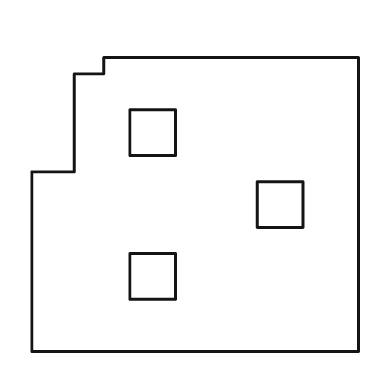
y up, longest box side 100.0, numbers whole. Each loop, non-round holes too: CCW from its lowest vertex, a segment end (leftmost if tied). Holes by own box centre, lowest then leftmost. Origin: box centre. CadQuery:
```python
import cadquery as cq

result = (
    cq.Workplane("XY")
    .moveTo(-50.0, -45.0)
    .lineTo(50.0, -45.0)
    .lineTo(50.0, 45.0)
    .lineTo(-28.0, 45.0)
    .lineTo(-28.0, 40.0)
    .lineTo(-37.0, 40.0)
    .lineTo(-37.0, 10.0)
    .lineTo(-50.0, 10.0)
    .close()
    .moveTo(-20.0, -29.0)
    .lineTo(-6.0, -29.0)
    .lineTo(-6.0, -15.0)
    .lineTo(-20.0, -15.0)
    .close()
    .moveTo(19.0, -7.0)
    .lineTo(33.0, -7.0)
    .lineTo(33.0, 7.0)
    .lineTo(19.0, 7.0)
    .close()
    .moveTo(-20.0, 15.0)
    .lineTo(-6.0, 15.0)
    .lineTo(-6.0, 29.0)
    .lineTo(-20.0, 29.0)
    .close()
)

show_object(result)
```